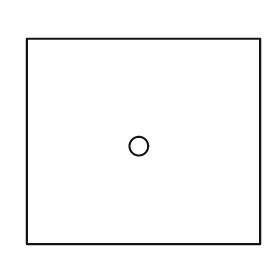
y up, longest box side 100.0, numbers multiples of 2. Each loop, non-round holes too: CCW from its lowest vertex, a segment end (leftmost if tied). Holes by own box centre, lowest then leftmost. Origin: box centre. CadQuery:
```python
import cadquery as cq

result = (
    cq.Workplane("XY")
    .moveTo(-50.0, -44.0)
    .lineTo(50.0, -44.0)
    .lineTo(50.0, 44.0)
    .lineTo(-50.0, 44.0)
    .close()
    .moveTo(-2.0, -2.0)
    .circle(4.0)
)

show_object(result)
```